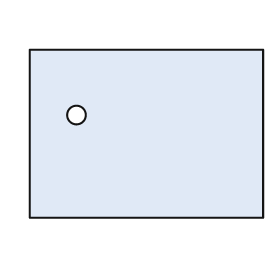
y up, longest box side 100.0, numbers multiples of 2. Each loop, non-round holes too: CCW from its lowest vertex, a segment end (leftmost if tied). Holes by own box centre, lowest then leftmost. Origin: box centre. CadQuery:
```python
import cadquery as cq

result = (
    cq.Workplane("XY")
    .moveTo(-50.0, -36.0)
    .lineTo(50.0, -36.0)
    .lineTo(50.0, 36.0)
    .lineTo(-50.0, 36.0)
    .close()
    .moveTo(-30.0, 8.0)
    .circle(4.0)
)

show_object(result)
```